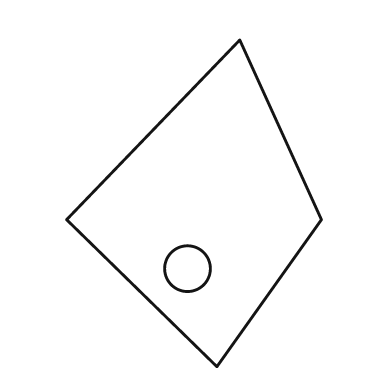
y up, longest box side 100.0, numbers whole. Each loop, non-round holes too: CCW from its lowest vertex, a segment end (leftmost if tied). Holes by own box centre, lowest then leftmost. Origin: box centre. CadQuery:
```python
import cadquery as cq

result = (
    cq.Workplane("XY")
    .moveTo(7.0, -50.0)
    .lineTo(39.0, -5.0)
    .lineTo(14.0, 50.0)
    .lineTo(-39.0, -5.0)
    .close()
    .moveTo(-2.0, -20.0)
    .circle(7.0)
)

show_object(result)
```